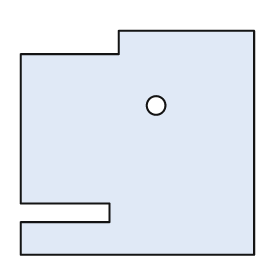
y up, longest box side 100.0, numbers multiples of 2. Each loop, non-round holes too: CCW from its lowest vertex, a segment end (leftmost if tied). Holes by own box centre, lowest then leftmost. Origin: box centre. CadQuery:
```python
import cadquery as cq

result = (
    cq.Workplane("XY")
    .moveTo(-50.0, -48.0)
    .lineTo(50.0, -48.0)
    .lineTo(50.0, 48.0)
    .lineTo(-8.0, 48.0)
    .lineTo(-8.0, 38.0)
    .lineTo(-50.0, 38.0)
    .lineTo(-50.0, -26.0)
    .lineTo(-12.0, -26.0)
    .lineTo(-12.0, -34.0)
    .lineTo(-50.0, -34.0)
    .close()
    .moveTo(8.0, 16.0)
    .circle(4.0)
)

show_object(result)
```